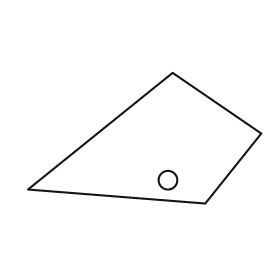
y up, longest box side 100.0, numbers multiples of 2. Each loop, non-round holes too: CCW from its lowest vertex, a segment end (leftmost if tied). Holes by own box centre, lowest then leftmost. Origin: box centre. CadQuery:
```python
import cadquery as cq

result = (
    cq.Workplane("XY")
    .moveTo(26.0, -28.0)
    .lineTo(50.0, 2.0)
    .lineTo(12.0, 28.0)
    .lineTo(-50.0, -22.0)
    .close()
    .moveTo(10.0, -18.0)
    .circle(4.0)
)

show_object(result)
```